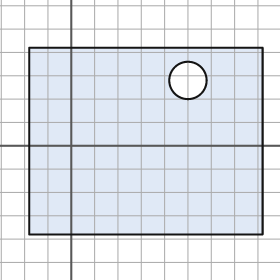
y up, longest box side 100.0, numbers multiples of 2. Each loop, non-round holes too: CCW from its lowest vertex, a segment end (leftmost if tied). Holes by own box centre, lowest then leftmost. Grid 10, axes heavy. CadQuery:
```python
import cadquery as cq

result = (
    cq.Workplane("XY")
    .moveTo(-18.0, -38.0)
    .lineTo(82.0, -38.0)
    .lineTo(82.0, 42.0)
    .lineTo(-18.0, 42.0)
    .close()
    .moveTo(50.0, 28.0)
    .circle(8.0)
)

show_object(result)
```